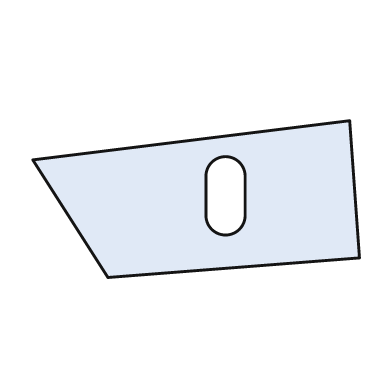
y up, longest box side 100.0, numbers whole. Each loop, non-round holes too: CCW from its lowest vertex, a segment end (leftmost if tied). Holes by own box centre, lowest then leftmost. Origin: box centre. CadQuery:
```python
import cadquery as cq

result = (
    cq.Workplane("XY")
    .moveTo(-27.0, -24.0)
    .lineTo(50.0, -18.0)
    .lineTo(47.0, 24.0)
    .lineTo(-50.0, 12.0)
    .close()
    .moveTo(3.0, -5.0)
    .threePointArc((9.0, -11.0), (15.0, -5.0))
    .lineTo(15.0, 7.0)
    .threePointArc((9.0, 13.0), (3.0, 7.0))
    .close()
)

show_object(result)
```